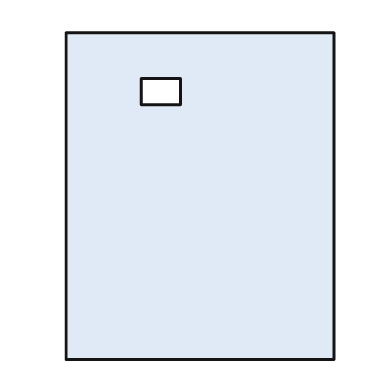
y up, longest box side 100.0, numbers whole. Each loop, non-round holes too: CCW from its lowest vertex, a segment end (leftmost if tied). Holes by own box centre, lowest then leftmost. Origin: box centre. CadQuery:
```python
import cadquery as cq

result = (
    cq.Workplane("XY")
    .moveTo(-41.0, -50.0)
    .lineTo(41.0, -50.0)
    .lineTo(41.0, 50.0)
    .lineTo(-41.0, 50.0)
    .close()
    .moveTo(-18.0, 28.0)
    .lineTo(-6.0, 28.0)
    .lineTo(-6.0, 36.0)
    .lineTo(-18.0, 36.0)
    .close()
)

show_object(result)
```